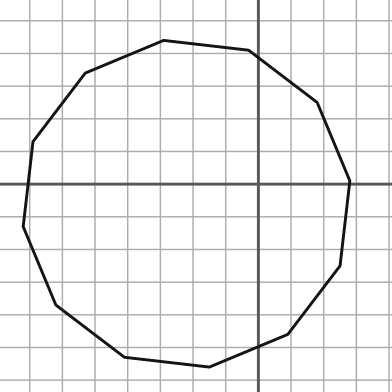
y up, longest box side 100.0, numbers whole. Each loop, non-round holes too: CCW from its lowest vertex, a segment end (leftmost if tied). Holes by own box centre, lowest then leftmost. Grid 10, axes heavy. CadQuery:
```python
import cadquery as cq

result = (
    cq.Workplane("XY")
    .moveTo(-15.0, -56.0)
    .lineTo(9.0, -46.0)
    .lineTo(25.0, -25.0)
    .lineTo(28.0, 1.0)
    .lineTo(18.0, 25.0)
    .lineTo(-3.0, 41.0)
    .lineTo(-29.0, 44.0)
    .lineTo(-53.0, 34.0)
    .lineTo(-69.0, 13.0)
    .lineTo(-72.0, -13.0)
    .lineTo(-62.0, -37.0)
    .lineTo(-41.0, -53.0)
    .close()
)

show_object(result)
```